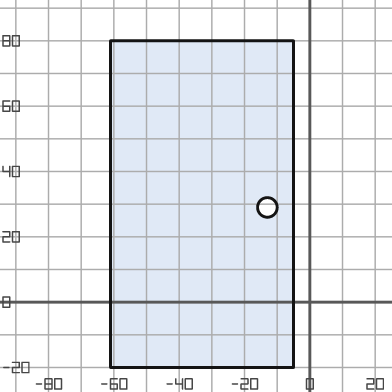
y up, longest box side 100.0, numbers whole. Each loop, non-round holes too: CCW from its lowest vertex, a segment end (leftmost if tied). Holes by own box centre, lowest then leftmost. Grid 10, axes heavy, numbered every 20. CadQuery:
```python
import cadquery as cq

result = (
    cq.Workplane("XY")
    .moveTo(-61.0, -20.0)
    .lineTo(-5.0, -20.0)
    .lineTo(-5.0, 80.0)
    .lineTo(-61.0, 80.0)
    .close()
    .moveTo(-13.0, 29.0)
    .circle(3.0)
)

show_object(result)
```